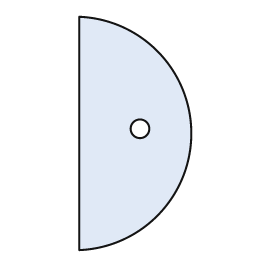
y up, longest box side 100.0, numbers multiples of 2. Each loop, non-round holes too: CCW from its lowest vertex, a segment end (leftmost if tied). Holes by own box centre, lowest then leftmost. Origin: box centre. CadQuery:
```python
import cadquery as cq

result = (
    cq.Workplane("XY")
    .moveTo(-24.0, -50.0)
    .threePointArc((24.0, 0.0), (-24.0, 50.0))
    .close()
    .moveTo(2.0, 2.0)
    .circle(4.0)
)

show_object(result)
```